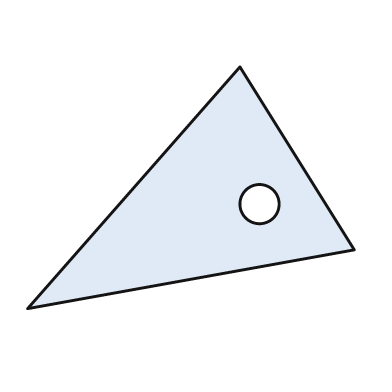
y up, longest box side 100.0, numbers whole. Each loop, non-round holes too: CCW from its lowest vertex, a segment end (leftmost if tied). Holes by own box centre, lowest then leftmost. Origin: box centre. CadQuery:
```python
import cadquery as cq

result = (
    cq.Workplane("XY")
    .moveTo(-50.0, -37.0)
    .lineTo(50.0, -19.0)
    .lineTo(15.0, 37.0)
    .close()
    .moveTo(21.0, -5.0)
    .circle(6.0)
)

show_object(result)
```